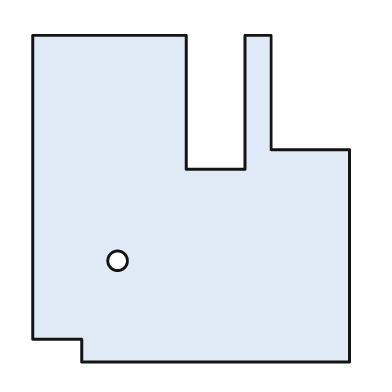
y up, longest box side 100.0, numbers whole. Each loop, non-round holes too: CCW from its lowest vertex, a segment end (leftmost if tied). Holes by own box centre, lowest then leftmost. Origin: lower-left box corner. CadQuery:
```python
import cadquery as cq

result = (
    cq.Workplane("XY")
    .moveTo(15.0, 0.0)
    .lineTo(97.0, 0.0)
    .lineTo(97.0, 65.0)
    .lineTo(73.0, 65.0)
    .lineTo(73.0, 100.0)
    .lineTo(65.0, 100.0)
    .lineTo(65.0, 59.0)
    .lineTo(47.0, 59.0)
    .lineTo(47.0, 100.0)
    .lineTo(0.0, 100.0)
    .lineTo(0.0, 7.0)
    .lineTo(15.0, 7.0)
    .close()
    .moveTo(26.0, 31.0)
    .circle(3.0)
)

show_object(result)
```